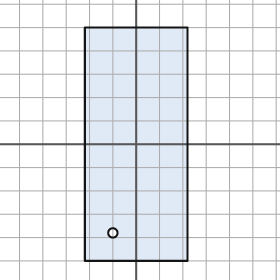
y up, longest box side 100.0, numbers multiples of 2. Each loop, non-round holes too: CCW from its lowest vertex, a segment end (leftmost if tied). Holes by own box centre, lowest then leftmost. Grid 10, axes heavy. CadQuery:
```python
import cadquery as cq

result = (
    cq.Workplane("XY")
    .moveTo(-22.0, -50.0)
    .lineTo(22.0, -50.0)
    .lineTo(22.0, 50.0)
    .lineTo(-22.0, 50.0)
    .close()
    .moveTo(-10.0, -38.0)
    .circle(2.0)
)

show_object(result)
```